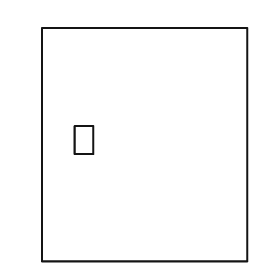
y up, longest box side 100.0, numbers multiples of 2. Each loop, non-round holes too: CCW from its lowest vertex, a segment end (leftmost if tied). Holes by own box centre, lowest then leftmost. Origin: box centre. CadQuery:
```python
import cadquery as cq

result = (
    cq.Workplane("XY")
    .moveTo(-44.0, -50.0)
    .lineTo(44.0, -50.0)
    .lineTo(44.0, 50.0)
    .lineTo(-44.0, 50.0)
    .close()
    .moveTo(-30.0, -4.0)
    .lineTo(-22.0, -4.0)
    .lineTo(-22.0, 8.0)
    .lineTo(-30.0, 8.0)
    .close()
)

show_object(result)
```